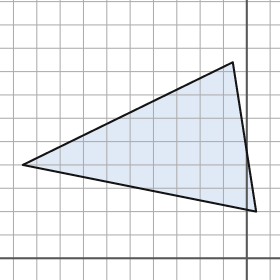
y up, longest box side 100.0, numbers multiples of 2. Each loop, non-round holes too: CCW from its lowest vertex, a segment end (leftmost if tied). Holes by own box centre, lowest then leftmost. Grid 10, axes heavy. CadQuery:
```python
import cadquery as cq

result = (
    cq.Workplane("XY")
    .moveTo(4.0, 20.0)
    .lineTo(-6.0, 84.0)
    .lineTo(-96.0, 40.0)
    .close()
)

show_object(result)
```